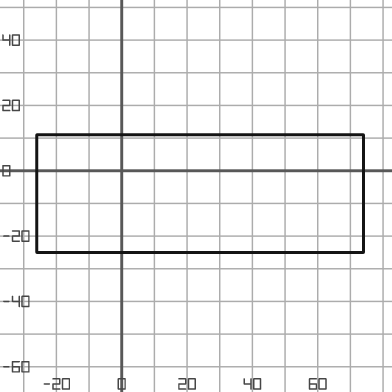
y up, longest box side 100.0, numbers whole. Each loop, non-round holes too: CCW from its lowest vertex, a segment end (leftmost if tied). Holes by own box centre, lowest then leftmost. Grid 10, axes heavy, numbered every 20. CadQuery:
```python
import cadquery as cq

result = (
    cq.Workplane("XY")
    .moveTo(-26.0, -25.0)
    .lineTo(74.0, -25.0)
    .lineTo(74.0, 11.0)
    .lineTo(-26.0, 11.0)
    .close()
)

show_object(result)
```